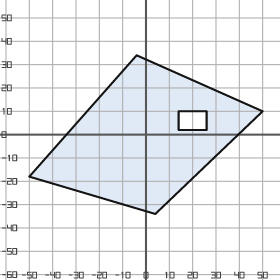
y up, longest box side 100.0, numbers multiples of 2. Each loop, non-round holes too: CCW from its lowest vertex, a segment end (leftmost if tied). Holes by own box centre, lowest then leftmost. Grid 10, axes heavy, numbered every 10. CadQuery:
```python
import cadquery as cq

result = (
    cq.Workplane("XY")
    .moveTo(4.0, -34.0)
    .lineTo(50.0, 10.0)
    .lineTo(-4.0, 34.0)
    .lineTo(-50.0, -18.0)
    .close()
    .moveTo(14.0, 2.0)
    .lineTo(26.0, 2.0)
    .lineTo(26.0, 10.0)
    .lineTo(14.0, 10.0)
    .close()
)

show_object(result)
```